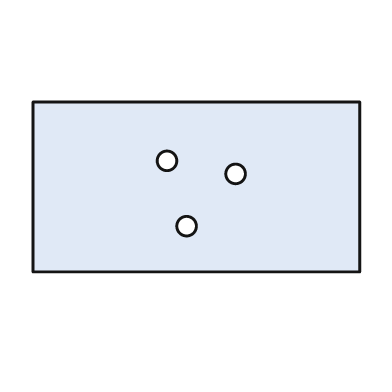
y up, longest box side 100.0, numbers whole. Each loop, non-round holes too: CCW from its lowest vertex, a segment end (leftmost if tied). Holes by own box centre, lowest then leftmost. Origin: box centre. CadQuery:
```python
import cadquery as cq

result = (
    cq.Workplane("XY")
    .moveTo(-50.0, -26.0)
    .lineTo(50.0, -26.0)
    .lineTo(50.0, 26.0)
    .lineTo(-50.0, 26.0)
    .close()
    .moveTo(-3.0, -12.0)
    .circle(3.0)
    .moveTo(12.0, 4.0)
    .circle(3.0)
    .moveTo(-9.0, 8.0)
    .circle(3.0)
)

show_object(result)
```